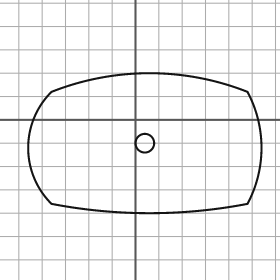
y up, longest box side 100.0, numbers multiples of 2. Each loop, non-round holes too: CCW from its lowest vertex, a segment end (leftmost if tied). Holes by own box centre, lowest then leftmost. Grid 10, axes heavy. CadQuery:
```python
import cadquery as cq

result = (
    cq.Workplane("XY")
    .moveTo(-36.0, -36.0)
    .threePointArc((6.0, -40.0), (48.0, -36.0))
    .threePointArc((54.0, -12.0), (48.0, 12.0))
    .threePointArc((6.0, 20.0), (-36.0, 12.0))
    .threePointArc((-46.0, -12.0), (-36.0, -36.0))
    .close()
    .moveTo(4.0, -10.0)
    .circle(4.0)
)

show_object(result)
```